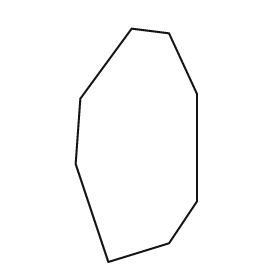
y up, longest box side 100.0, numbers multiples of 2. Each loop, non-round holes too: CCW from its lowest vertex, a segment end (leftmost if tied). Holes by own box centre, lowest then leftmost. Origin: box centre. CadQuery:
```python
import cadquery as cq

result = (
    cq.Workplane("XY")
    .moveTo(-12.0, -50.0)
    .lineTo(14.0, -42.0)
    .lineTo(26.0, -24.0)
    .lineTo(26.0, 22.0)
    .lineTo(14.0, 48.0)
    .lineTo(-2.0, 50.0)
    .lineTo(-24.0, 20.0)
    .lineTo(-26.0, -8.0)
    .close()
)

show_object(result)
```